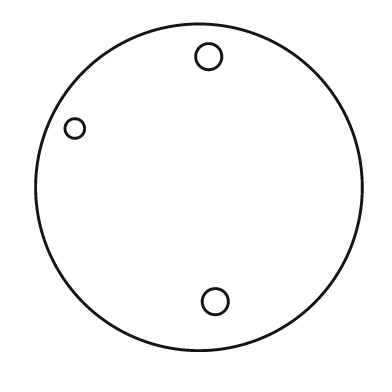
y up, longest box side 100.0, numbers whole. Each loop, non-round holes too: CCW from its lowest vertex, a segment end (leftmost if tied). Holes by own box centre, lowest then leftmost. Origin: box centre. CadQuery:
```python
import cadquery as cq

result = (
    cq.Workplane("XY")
    .moveTo(0.0, 0.0)
    .circle(50.0)
    .moveTo(5.0, -35.0)
    .circle(4.0)
    .moveTo(-38.0, 18.0)
    .circle(3.0)
    .moveTo(3.0, 40.0)
    .circle(4.0)
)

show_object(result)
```